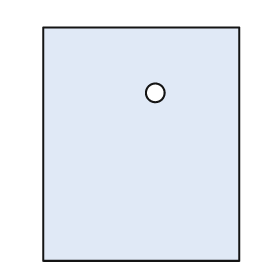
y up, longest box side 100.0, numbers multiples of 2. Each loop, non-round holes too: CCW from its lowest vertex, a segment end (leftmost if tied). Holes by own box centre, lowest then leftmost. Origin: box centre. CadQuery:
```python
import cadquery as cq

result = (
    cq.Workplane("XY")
    .moveTo(-42.0, -50.0)
    .lineTo(42.0, -50.0)
    .lineTo(42.0, 50.0)
    .lineTo(-42.0, 50.0)
    .close()
    .moveTo(6.0, 22.0)
    .circle(4.0)
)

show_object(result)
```